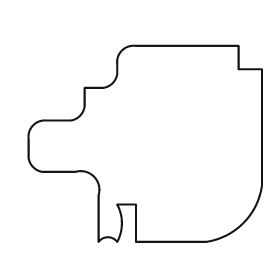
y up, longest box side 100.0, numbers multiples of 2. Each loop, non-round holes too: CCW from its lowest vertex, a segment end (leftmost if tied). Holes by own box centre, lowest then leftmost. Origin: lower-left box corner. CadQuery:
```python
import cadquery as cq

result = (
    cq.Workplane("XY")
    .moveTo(30.0, 0.0)
    .threePointArc((34.0, 2.0), (38.0, 0.0))
    .threePointArc((40.0, 8.0), (38.0, 16.0))
    .lineTo(46.0, 16.0)
    .lineTo(46.0, 0.0)
    .lineTo(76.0, 0.0)
    .threePointArc((92.0, 8.0), (100.0, 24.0))
    .lineTo(100.0, 74.0)
    .lineTo(90.0, 74.0)
    .lineTo(90.0, 84.0)
    .lineTo(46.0, 84.0)
    .threePointArc((40.0, 82.0), (38.0, 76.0))
    .lineTo(38.0, 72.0)
    .threePointArc((36.0, 68.0), (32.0, 66.0))
    .lineTo(24.0, 66.0)
    .lineTo(24.0, 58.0)
    .threePointArc((22.0, 54.0), (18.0, 52.0))
    .lineTo(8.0, 52.0)
    .threePointArc((2.0, 50.0), (0.0, 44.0))
    .lineTo(0.0, 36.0)
    .threePointArc((2.0, 32.0), (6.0, 30.0))
    .lineTo(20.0, 30.0)
    .threePointArc((28.0, 28.0), (30.0, 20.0))
    .close()
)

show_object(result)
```